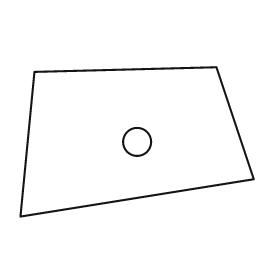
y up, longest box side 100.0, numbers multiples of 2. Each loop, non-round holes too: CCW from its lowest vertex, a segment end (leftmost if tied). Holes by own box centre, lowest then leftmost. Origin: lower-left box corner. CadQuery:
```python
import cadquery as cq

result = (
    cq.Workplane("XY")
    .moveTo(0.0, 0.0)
    .lineTo(100.0, 16.0)
    .lineTo(84.0, 64.0)
    .lineTo(6.0, 62.0)
    .close()
    .moveTo(50.0, 32.0)
    .circle(6.0)
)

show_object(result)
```